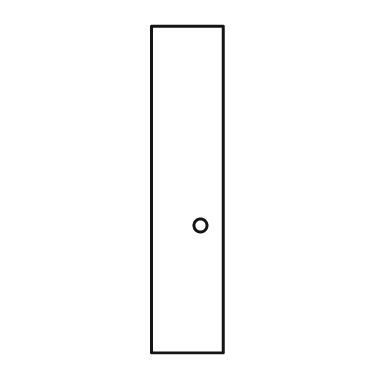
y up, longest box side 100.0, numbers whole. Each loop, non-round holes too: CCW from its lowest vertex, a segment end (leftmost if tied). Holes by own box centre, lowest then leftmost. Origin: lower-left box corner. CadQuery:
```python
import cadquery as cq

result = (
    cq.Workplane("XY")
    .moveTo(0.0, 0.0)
    .lineTo(22.0, 0.0)
    .lineTo(22.0, 100.0)
    .lineTo(0.0, 100.0)
    .close()
    .moveTo(15.0, 39.0)
    .circle(2.0)
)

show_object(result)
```